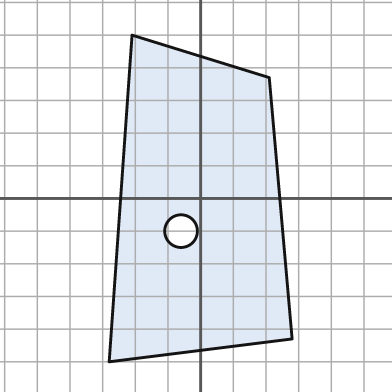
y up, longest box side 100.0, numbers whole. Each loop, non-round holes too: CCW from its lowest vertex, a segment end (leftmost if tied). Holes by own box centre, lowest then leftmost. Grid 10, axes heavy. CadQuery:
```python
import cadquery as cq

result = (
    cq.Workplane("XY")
    .moveTo(-28.0, -50.0)
    .lineTo(28.0, -43.0)
    .lineTo(21.0, 37.0)
    .lineTo(-21.0, 50.0)
    .close()
    .moveTo(-6.0, -10.0)
    .circle(5.0)
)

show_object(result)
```